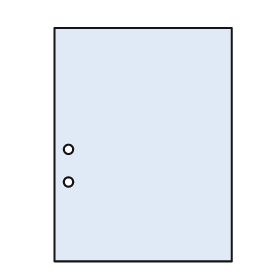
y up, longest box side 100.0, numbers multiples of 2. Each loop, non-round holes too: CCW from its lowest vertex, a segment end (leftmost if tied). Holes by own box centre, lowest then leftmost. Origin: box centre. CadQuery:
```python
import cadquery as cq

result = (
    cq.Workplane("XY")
    .moveTo(-38.0, -50.0)
    .lineTo(38.0, -50.0)
    .lineTo(38.0, 50.0)
    .lineTo(-38.0, 50.0)
    .close()
    .moveTo(-32.0, -16.0)
    .circle(2.0)
    .moveTo(-32.0, -2.0)
    .circle(2.0)
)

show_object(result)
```